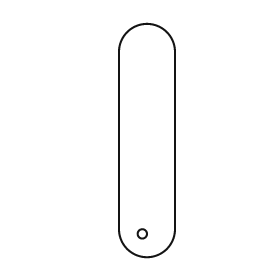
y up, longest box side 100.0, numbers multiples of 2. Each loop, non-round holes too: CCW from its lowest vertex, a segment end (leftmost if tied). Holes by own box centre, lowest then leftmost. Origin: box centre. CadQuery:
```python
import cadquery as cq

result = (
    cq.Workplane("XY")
    .moveTo(-12.0, -38.0)
    .threePointArc((0.0, -50.0), (12.0, -38.0))
    .lineTo(12.0, 38.0)
    .threePointArc((0.0, 50.0), (-12.0, 38.0))
    .close()
    .moveTo(-2.0, -40.0)
    .circle(2.0)
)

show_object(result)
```